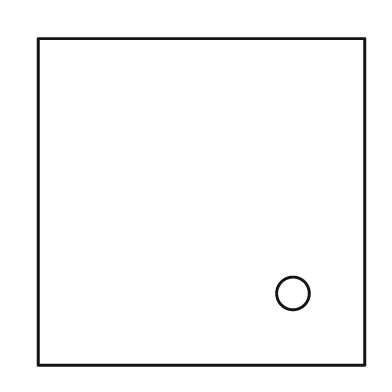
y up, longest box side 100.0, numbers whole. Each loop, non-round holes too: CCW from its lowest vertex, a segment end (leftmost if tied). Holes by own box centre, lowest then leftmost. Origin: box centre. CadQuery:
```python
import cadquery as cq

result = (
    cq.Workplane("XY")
    .moveTo(-50.0, -50.0)
    .lineTo(50.0, -50.0)
    .lineTo(50.0, 50.0)
    .lineTo(-50.0, 50.0)
    .close()
    .moveTo(28.0, -28.0)
    .circle(5.0)
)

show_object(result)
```